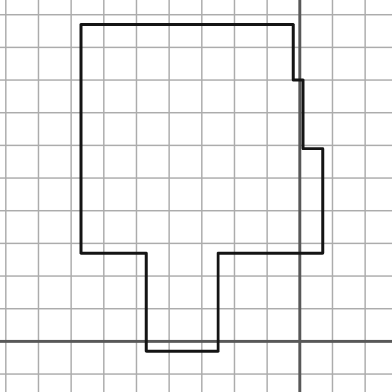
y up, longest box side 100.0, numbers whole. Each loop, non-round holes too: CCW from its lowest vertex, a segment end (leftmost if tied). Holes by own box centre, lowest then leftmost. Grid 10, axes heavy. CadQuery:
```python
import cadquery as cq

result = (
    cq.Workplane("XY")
    .moveTo(-47.0, -3.0)
    .lineTo(-25.0, -3.0)
    .lineTo(-25.0, 27.0)
    .lineTo(7.0, 27.0)
    .lineTo(7.0, 59.0)
    .lineTo(1.0, 59.0)
    .lineTo(1.0, 80.0)
    .lineTo(-2.0, 80.0)
    .lineTo(-2.0, 97.0)
    .lineTo(-67.0, 97.0)
    .lineTo(-67.0, 27.0)
    .lineTo(-47.0, 27.0)
    .close()
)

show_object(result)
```